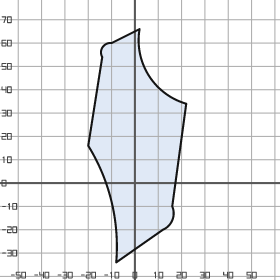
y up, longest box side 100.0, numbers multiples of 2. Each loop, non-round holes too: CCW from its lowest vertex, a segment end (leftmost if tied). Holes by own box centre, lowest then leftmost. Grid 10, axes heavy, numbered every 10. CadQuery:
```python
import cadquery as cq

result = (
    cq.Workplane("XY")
    .moveTo(-8.0, -34.0)
    .lineTo(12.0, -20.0)
    .threePointArc((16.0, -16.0), (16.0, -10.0))
    .lineTo(22.0, 34.0)
    .threePointArc((6.0, 46.0), (2.0, 66.0))
    .lineTo(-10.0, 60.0)
    .threePointArc((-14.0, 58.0), (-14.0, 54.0))
    .lineTo(-20.0, 16.0)
    .threePointArc((-10.0, -8.0), (-8.0, -34.0))
    .close()
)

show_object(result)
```